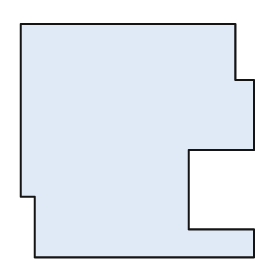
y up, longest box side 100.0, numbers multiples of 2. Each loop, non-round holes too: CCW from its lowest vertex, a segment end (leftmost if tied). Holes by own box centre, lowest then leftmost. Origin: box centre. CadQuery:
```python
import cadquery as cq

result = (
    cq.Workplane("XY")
    .moveTo(-44.0, -50.0)
    .lineTo(50.0, -50.0)
    .lineTo(50.0, -38.0)
    .lineTo(22.0, -38.0)
    .lineTo(22.0, -4.0)
    .lineTo(50.0, -4.0)
    .lineTo(50.0, 26.0)
    .lineTo(42.0, 26.0)
    .lineTo(42.0, 50.0)
    .lineTo(-50.0, 50.0)
    .lineTo(-50.0, -24.0)
    .lineTo(-44.0, -24.0)
    .close()
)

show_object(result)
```